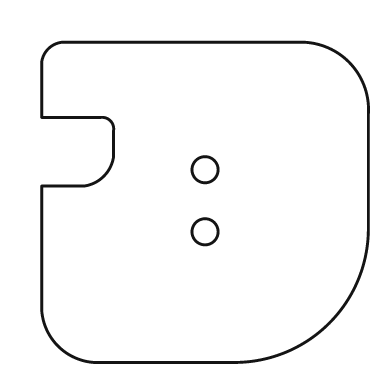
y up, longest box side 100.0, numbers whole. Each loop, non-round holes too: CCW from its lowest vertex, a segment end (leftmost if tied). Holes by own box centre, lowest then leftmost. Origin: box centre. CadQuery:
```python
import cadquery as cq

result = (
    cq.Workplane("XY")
    .moveTo(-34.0, -49.0)
    .lineTo(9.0, -49.0)
    .threePointArc((38.0, -37.0), (50.0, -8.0))
    .lineTo(50.0, 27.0)
    .threePointArc((44.0, 43.0), (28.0, 49.0))
    .lineTo(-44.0, 49.0)
    .threePointArc((-48.0, 47.0), (-50.0, 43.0))
    .lineTo(-50.0, 26.0)
    .lineTo(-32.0, 26.0)
    .threePointArc((-29.0, 25.0), (-28.0, 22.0))
    .lineTo(-28.0, 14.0)
    .threePointArc((-31.0, 8.0), (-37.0, 5.0))
    .lineTo(-50.0, 5.0)
    .lineTo(-50.0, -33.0)
    .threePointArc((-45.0, -44.0), (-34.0, -49.0))
    .close()
    .moveTo(0.0, -9.0)
    .circle(4.0)
    .moveTo(0.0, 10.0)
    .circle(4.0)
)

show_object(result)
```